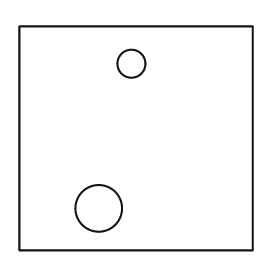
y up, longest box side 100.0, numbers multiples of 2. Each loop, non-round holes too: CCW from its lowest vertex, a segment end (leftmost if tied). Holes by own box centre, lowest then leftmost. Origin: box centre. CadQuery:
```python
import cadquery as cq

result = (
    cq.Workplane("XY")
    .moveTo(-50.0, -48.0)
    .lineTo(50.0, -48.0)
    .lineTo(50.0, 48.0)
    .lineTo(-50.0, 48.0)
    .close()
    .moveTo(-16.0, -30.0)
    .circle(10.0)
    .moveTo(-2.0, 32.0)
    .circle(6.0)
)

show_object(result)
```